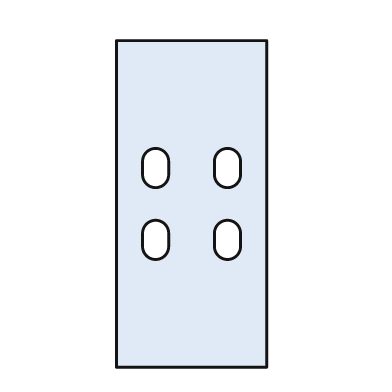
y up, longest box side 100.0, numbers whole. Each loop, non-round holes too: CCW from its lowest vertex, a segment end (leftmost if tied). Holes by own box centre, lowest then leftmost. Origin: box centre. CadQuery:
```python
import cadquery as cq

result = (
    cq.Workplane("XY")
    .moveTo(-23.0, -50.0)
    .lineTo(23.0, -50.0)
    .lineTo(23.0, 50.0)
    .lineTo(-23.0, 50.0)
    .close()
    .moveTo(-15.0, -13.0)
    .threePointArc((-11.0, -17.0), (-7.0, -13.0))
    .lineTo(-7.0, -9.0)
    .threePointArc((-11.0, -5.0), (-15.0, -9.0))
    .close()
    .moveTo(7.0, -13.0)
    .threePointArc((11.0, -17.0), (15.0, -13.0))
    .lineTo(15.0, -9.0)
    .threePointArc((11.0, -5.0), (7.0, -9.0))
    .close()
    .moveTo(-15.0, 9.0)
    .threePointArc((-11.0, 5.0), (-7.0, 9.0))
    .lineTo(-7.0, 13.0)
    .threePointArc((-11.0, 17.0), (-15.0, 13.0))
    .close()
    .moveTo(7.0, 9.0)
    .threePointArc((11.0, 5.0), (15.0, 9.0))
    .lineTo(15.0, 13.0)
    .threePointArc((11.0, 17.0), (7.0, 13.0))
    .close()
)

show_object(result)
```